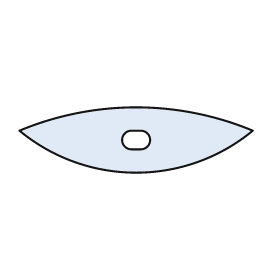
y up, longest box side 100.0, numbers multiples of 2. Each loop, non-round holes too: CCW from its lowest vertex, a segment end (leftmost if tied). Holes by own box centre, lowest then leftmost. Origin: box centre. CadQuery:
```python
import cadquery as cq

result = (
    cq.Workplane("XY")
    .moveTo(-50.0, 4.0)
    .threePointArc((0.0, -14.0), (50.0, 4.0))
    .threePointArc((0.0, 14.0), (-50.0, 4.0))
    .close()
    .moveTo(-2.0, -4.0)
    .lineTo(2.0, -4.0)
    .threePointArc((6.0, 0.0), (2.0, 4.0))
    .lineTo(-2.0, 4.0)
    .threePointArc((-6.0, 0.0), (-2.0, -4.0))
    .close()
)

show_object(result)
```